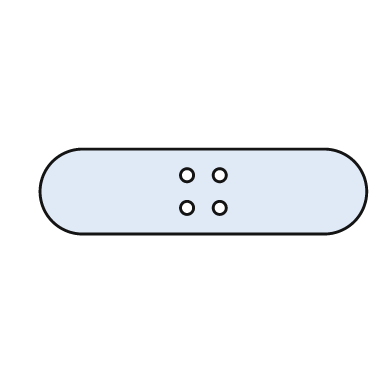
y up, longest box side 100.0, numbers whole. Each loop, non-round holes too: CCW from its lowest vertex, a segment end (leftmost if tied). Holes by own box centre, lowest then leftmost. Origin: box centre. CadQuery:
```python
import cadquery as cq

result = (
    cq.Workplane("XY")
    .moveTo(-37.0, -13.0)
    .lineTo(37.0, -13.0)
    .threePointArc((50.0, 0.0), (37.0, 13.0))
    .lineTo(-37.0, 13.0)
    .threePointArc((-50.0, 0.0), (-37.0, -13.0))
    .close()
    .moveTo(-5.0, -5.0)
    .circle(2.0)
    .moveTo(5.0, -5.0)
    .circle(2.0)
    .moveTo(-5.0, 5.0)
    .circle(2.0)
    .moveTo(5.0, 5.0)
    .circle(2.0)
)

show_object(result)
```